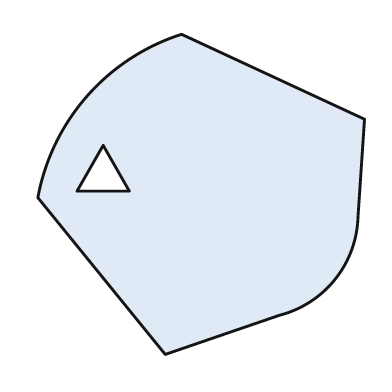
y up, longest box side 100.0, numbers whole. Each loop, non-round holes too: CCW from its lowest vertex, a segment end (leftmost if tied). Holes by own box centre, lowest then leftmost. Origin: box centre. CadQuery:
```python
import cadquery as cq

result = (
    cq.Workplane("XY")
    .moveTo(-11.0, -49.0)
    .lineTo(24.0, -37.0)
    .threePointArc((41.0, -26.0), (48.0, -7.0))
    .lineTo(50.0, 23.0)
    .lineTo(-6.0, 49.0)
    .threePointArc((-35.0, 30.0), (-50.0, -1.0))
    .close()
    .moveTo(-38.0, 1.0)
    .lineTo(-22.0, 1.0)
    .lineTo(-30.0, 15.0)
    .close()
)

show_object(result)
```